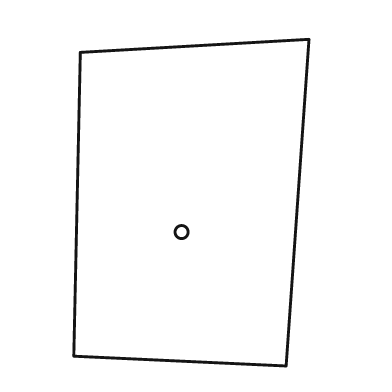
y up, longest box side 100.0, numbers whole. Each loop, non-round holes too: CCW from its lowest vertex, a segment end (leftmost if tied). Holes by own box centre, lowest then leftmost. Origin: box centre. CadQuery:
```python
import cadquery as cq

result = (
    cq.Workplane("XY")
    .moveTo(29.0, -50.0)
    .lineTo(36.0, 50.0)
    .lineTo(-34.0, 46.0)
    .lineTo(-36.0, -47.0)
    .close()
    .moveTo(-3.0, -9.0)
    .circle(2.0)
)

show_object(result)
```